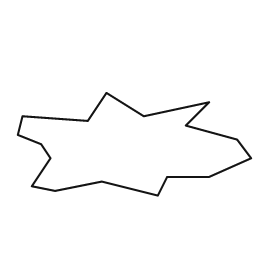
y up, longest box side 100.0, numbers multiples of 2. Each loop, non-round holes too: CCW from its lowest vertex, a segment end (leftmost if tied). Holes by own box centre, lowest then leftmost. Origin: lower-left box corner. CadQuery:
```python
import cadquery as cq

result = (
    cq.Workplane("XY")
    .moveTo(60.0, 0.0)
    .lineTo(64.0, 8.0)
    .lineTo(82.0, 8.0)
    .lineTo(100.0, 16.0)
    .lineTo(94.0, 24.0)
    .lineTo(72.0, 30.0)
    .lineTo(82.0, 40.0)
    .lineTo(54.0, 34.0)
    .lineTo(38.0, 44.0)
    .lineTo(30.0, 32.0)
    .lineTo(2.0, 34.0)
    .lineTo(0.0, 26.0)
    .lineTo(10.0, 22.0)
    .lineTo(14.0, 16.0)
    .lineTo(6.0, 4.0)
    .lineTo(16.0, 2.0)
    .lineTo(36.0, 6.0)
    .close()
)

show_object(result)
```